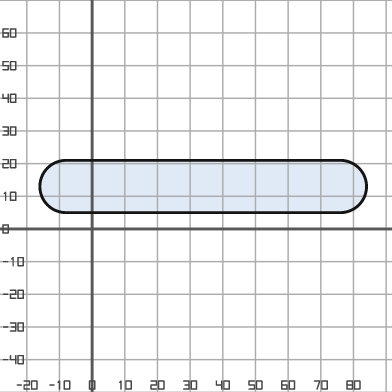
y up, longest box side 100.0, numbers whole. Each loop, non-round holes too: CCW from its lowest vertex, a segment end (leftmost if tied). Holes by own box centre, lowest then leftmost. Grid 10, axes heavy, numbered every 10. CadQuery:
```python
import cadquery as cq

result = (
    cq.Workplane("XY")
    .moveTo(-8.0, 5.0)
    .lineTo(76.0, 5.0)
    .threePointArc((84.0, 13.0), (76.0, 21.0))
    .lineTo(-8.0, 21.0)
    .threePointArc((-16.0, 13.0), (-8.0, 5.0))
    .close()
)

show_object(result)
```